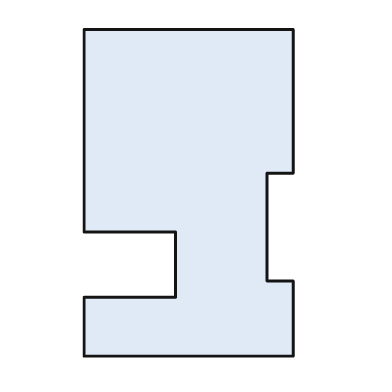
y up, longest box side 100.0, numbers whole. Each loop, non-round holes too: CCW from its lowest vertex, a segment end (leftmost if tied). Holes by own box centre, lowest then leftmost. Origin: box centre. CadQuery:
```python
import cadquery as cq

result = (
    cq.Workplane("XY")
    .moveTo(-32.0, -50.0)
    .lineTo(32.0, -50.0)
    .lineTo(32.0, -27.0)
    .lineTo(24.0, -27.0)
    .lineTo(24.0, 6.0)
    .lineTo(32.0, 6.0)
    .lineTo(32.0, 50.0)
    .lineTo(-32.0, 50.0)
    .lineTo(-32.0, -12.0)
    .lineTo(-4.0, -12.0)
    .lineTo(-4.0, -32.0)
    .lineTo(-32.0, -32.0)
    .close()
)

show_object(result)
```